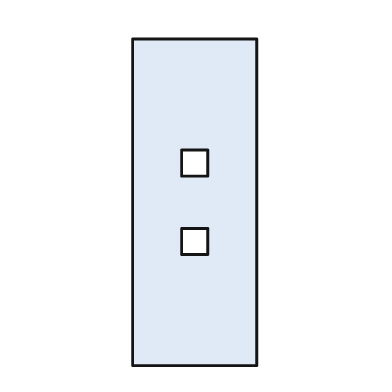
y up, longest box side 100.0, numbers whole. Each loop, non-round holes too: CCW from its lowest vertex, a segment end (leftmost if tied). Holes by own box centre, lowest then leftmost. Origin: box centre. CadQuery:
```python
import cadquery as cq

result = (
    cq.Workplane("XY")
    .moveTo(-19.0, -50.0)
    .lineTo(19.0, -50.0)
    .lineTo(19.0, 50.0)
    .lineTo(-19.0, 50.0)
    .close()
    .moveTo(-4.0, -16.0)
    .lineTo(4.0, -16.0)
    .lineTo(4.0, -8.0)
    .lineTo(-4.0, -8.0)
    .close()
    .moveTo(-4.0, 8.0)
    .lineTo(4.0, 8.0)
    .lineTo(4.0, 16.0)
    .lineTo(-4.0, 16.0)
    .close()
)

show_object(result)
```